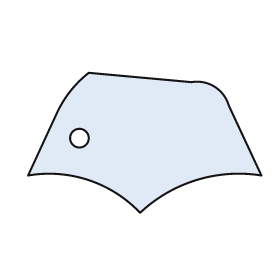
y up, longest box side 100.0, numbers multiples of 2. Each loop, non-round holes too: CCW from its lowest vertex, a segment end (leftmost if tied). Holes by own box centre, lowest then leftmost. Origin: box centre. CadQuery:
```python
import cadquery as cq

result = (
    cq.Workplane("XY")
    .moveTo(-2.0, -30.0)
    .threePointArc((22.0, -16.0), (50.0, -14.0))
    .lineTo(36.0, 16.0)
    .threePointArc((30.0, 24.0), (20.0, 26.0))
    .lineTo(-24.0, 30.0)
    .threePointArc((-32.0, 22.0), (-38.0, 12.0))
    .lineTo(-50.0, -14.0)
    .threePointArc((-24.0, -16.0), (-2.0, -30.0))
    .close()
    .moveTo(-28.0, 2.0)
    .circle(4.0)
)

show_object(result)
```